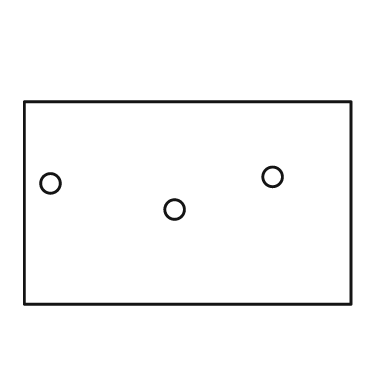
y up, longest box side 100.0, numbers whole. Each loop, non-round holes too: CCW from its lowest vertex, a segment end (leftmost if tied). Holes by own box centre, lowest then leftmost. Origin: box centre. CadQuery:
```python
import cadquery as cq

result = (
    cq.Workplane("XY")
    .moveTo(-50.0, -31.0)
    .lineTo(50.0, -31.0)
    .lineTo(50.0, 31.0)
    .lineTo(-50.0, 31.0)
    .close()
    .moveTo(-4.0, -2.0)
    .circle(3.0)
    .moveTo(-42.0, 6.0)
    .circle(3.0)
    .moveTo(26.0, 8.0)
    .circle(3.0)
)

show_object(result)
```